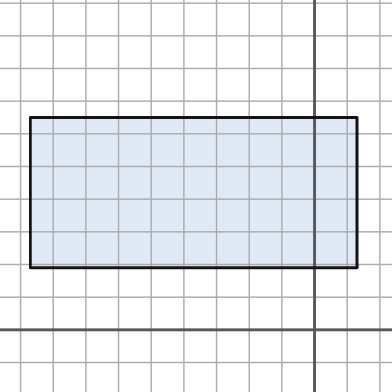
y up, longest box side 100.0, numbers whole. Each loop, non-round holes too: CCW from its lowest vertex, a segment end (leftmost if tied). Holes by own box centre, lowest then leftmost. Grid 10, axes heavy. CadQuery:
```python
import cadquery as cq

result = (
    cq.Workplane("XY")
    .moveTo(-87.0, 19.0)
    .lineTo(13.0, 19.0)
    .lineTo(13.0, 65.0)
    .lineTo(-87.0, 65.0)
    .close()
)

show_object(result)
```